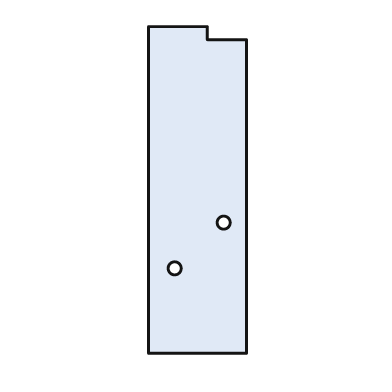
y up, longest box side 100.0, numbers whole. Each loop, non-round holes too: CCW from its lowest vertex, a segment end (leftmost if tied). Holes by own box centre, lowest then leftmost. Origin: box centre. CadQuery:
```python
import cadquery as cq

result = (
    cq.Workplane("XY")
    .moveTo(-15.0, -50.0)
    .lineTo(15.0, -50.0)
    .lineTo(15.0, 46.0)
    .lineTo(3.0, 46.0)
    .lineTo(3.0, 50.0)
    .lineTo(-15.0, 50.0)
    .close()
    .moveTo(-7.0, -24.0)
    .circle(2.0)
    .moveTo(8.0, -10.0)
    .circle(2.0)
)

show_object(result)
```